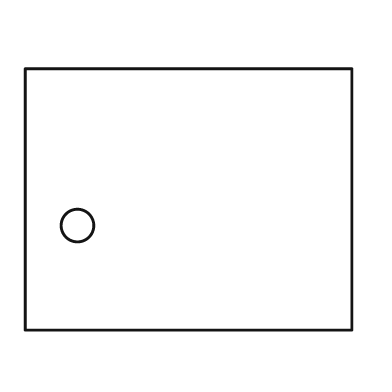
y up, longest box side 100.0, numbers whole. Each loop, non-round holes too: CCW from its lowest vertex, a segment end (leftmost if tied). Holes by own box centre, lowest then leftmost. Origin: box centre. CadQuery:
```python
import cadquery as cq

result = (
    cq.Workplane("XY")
    .moveTo(-50.0, -40.0)
    .lineTo(50.0, -40.0)
    .lineTo(50.0, 40.0)
    .lineTo(-50.0, 40.0)
    .close()
    .moveTo(-34.0, -8.0)
    .circle(5.0)
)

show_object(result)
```